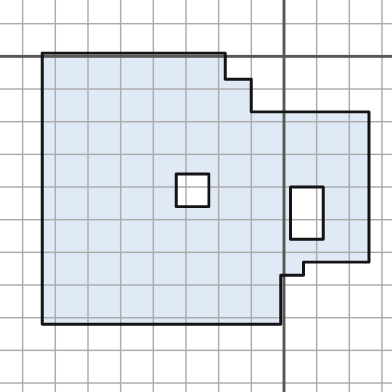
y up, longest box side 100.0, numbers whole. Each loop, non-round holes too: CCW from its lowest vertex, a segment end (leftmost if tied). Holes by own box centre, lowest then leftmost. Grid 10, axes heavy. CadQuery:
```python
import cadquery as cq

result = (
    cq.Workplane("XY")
    .moveTo(-74.0, -82.0)
    .lineTo(-1.0, -82.0)
    .lineTo(-1.0, -67.0)
    .lineTo(6.0, -67.0)
    .lineTo(6.0, -63.0)
    .lineTo(26.0, -63.0)
    .lineTo(26.0, -17.0)
    .lineTo(-10.0, -17.0)
    .lineTo(-10.0, -7.0)
    .lineTo(-18.0, -7.0)
    .lineTo(-18.0, 1.0)
    .lineTo(-74.0, 1.0)
    .close()
    .moveTo(2.0, -56.0)
    .lineTo(12.0, -56.0)
    .lineTo(12.0, -40.0)
    .lineTo(2.0, -40.0)
    .close()
    .moveTo(-33.0, -46.0)
    .lineTo(-23.0, -46.0)
    .lineTo(-23.0, -36.0)
    .lineTo(-33.0, -36.0)
    .close()
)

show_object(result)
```